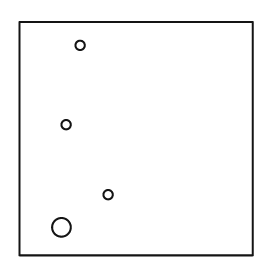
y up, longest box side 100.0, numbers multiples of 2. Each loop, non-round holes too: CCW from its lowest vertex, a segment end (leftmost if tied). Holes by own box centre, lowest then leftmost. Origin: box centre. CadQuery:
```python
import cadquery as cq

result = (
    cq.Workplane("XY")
    .moveTo(-50.0, -50.0)
    .lineTo(50.0, -50.0)
    .lineTo(50.0, 50.0)
    .lineTo(-50.0, 50.0)
    .close()
    .moveTo(-32.0, -38.0)
    .circle(4.0)
    .moveTo(-12.0, -24.0)
    .circle(2.0)
    .moveTo(-30.0, 6.0)
    .circle(2.0)
    .moveTo(-24.0, 40.0)
    .circle(2.0)
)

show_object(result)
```